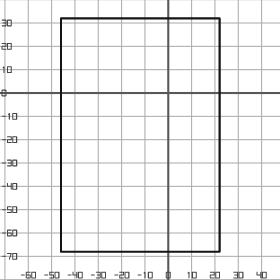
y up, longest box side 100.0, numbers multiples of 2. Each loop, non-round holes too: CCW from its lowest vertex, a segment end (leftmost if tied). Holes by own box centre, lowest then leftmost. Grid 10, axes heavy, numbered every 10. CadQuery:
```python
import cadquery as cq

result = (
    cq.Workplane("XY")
    .moveTo(-46.0, -68.0)
    .lineTo(22.0, -68.0)
    .lineTo(22.0, 32.0)
    .lineTo(-46.0, 32.0)
    .close()
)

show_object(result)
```